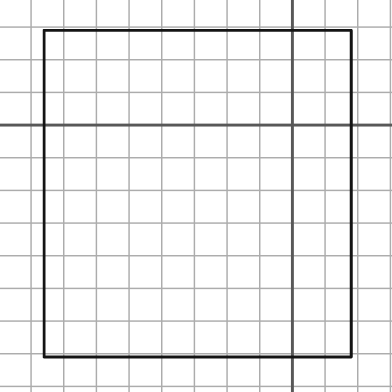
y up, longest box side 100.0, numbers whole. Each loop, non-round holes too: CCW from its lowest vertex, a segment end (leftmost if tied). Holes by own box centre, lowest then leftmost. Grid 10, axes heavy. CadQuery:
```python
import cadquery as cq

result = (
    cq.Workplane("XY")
    .moveTo(-76.0, -71.0)
    .lineTo(18.0, -71.0)
    .lineTo(18.0, 29.0)
    .lineTo(-76.0, 29.0)
    .close()
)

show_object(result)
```